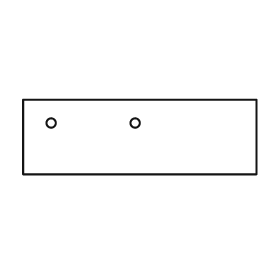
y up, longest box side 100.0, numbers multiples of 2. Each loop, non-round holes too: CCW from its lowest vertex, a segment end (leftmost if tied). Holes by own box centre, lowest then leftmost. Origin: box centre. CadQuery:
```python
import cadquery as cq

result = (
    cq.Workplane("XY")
    .moveTo(-50.0, -16.0)
    .lineTo(50.0, -16.0)
    .lineTo(50.0, 16.0)
    .lineTo(-50.0, 16.0)
    .close()
    .moveTo(-38.0, 6.0)
    .circle(2.0)
    .moveTo(-2.0, 6.0)
    .circle(2.0)
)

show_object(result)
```